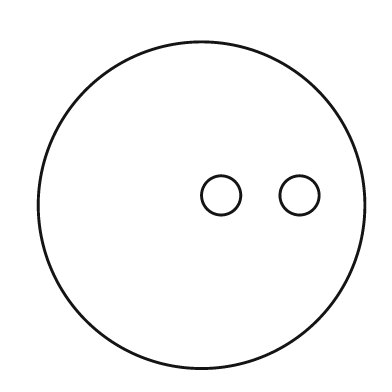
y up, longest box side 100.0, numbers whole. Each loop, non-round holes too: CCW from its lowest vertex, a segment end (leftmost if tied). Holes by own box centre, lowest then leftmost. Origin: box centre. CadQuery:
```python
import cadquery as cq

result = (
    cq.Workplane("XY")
    .moveTo(0.0, 0.0)
    .circle(50.0)
    .moveTo(6.0, 3.0)
    .circle(6.0)
    .moveTo(30.0, 3.0)
    .circle(6.0)
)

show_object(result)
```